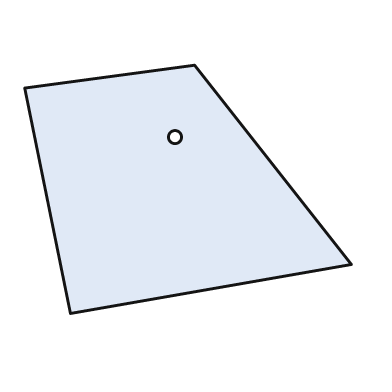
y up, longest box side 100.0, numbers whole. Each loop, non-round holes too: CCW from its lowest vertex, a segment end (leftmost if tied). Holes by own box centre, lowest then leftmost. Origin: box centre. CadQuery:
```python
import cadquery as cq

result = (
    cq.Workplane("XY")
    .moveTo(-36.0, -38.0)
    .lineTo(50.0, -23.0)
    .lineTo(2.0, 38.0)
    .lineTo(-50.0, 31.0)
    .close()
    .moveTo(-4.0, 16.0)
    .circle(2.0)
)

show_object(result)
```